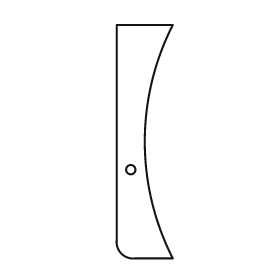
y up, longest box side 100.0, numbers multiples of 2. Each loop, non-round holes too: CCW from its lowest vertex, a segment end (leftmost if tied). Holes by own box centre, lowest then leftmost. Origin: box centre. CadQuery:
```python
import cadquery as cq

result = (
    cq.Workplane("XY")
    .moveTo(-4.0, -50.0)
    .lineTo(12.0, -50.0)
    .threePointArc((0.0, 0.0), (12.0, 50.0))
    .lineTo(-12.0, 50.0)
    .lineTo(-12.0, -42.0)
    .threePointArc((-10.0, -48.0), (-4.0, -50.0))
    .close()
    .moveTo(-6.0, -12.0)
    .circle(2.0)
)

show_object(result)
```